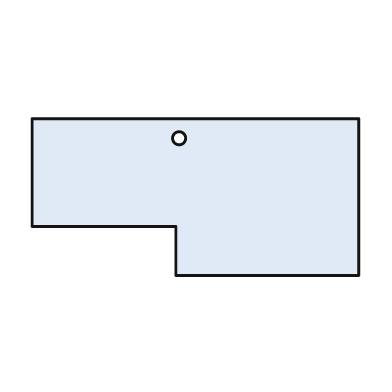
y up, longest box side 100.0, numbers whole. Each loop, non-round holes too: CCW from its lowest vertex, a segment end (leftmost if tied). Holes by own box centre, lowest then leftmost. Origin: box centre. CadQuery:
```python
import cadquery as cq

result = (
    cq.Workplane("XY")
    .moveTo(-6.0, -24.0)
    .lineTo(50.0, -24.0)
    .lineTo(50.0, 24.0)
    .lineTo(-50.0, 24.0)
    .lineTo(-50.0, -9.0)
    .lineTo(-6.0, -9.0)
    .close()
    .moveTo(-5.0, 18.0)
    .circle(2.0)
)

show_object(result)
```